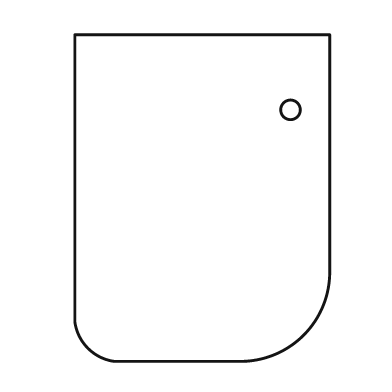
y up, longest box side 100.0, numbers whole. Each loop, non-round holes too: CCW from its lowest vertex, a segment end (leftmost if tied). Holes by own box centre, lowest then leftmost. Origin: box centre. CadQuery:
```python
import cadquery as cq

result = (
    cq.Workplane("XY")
    .moveTo(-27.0, -50.0)
    .lineTo(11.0, -50.0)
    .threePointArc((31.0, -42.0), (39.0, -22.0))
    .lineTo(39.0, 50.0)
    .lineTo(-39.0, 50.0)
    .lineTo(-39.0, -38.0)
    .threePointArc((-35.0, -46.0), (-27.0, -50.0))
    .close()
    .moveTo(27.0, 27.0)
    .circle(3.0)
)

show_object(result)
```